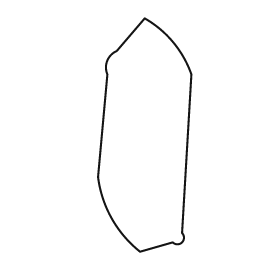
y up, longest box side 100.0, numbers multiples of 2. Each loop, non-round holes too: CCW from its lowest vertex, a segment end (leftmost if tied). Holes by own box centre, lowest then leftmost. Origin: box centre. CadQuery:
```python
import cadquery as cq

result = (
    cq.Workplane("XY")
    .moveTo(-2.0, -50.0)
    .lineTo(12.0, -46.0)
    .threePointArc((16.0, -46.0), (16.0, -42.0))
    .lineTo(20.0, 26.0)
    .threePointArc((12.0, 40.0), (0.0, 50.0))
    .lineTo(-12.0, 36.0)
    .threePointArc((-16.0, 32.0), (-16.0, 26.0))
    .lineTo(-20.0, -18.0)
    .threePointArc((-14.0, -36.0), (-2.0, -50.0))
    .close()
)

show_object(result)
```